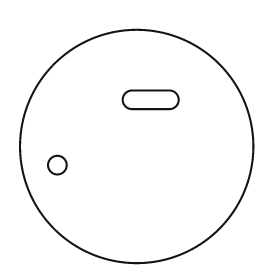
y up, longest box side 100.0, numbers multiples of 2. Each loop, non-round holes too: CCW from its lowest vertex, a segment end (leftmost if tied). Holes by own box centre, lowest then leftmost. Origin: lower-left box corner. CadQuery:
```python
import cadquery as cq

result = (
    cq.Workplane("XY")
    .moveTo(50.0, 50.0)
    .circle(50.0)
    .moveTo(16.0, 42.0)
    .circle(4.0)
    .moveTo(48.0, 66.0)
    .lineTo(64.0, 66.0)
    .threePointArc((68.0, 70.0), (64.0, 74.0))
    .lineTo(48.0, 74.0)
    .threePointArc((44.0, 70.0), (48.0, 66.0))
    .close()
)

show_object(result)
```